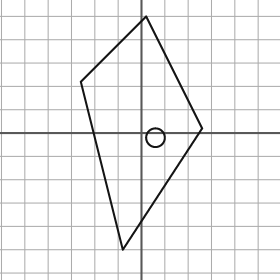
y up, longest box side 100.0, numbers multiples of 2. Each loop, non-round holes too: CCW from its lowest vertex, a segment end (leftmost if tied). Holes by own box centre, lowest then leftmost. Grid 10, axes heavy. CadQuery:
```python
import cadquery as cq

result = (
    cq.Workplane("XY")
    .moveTo(-8.0, -50.0)
    .lineTo(26.0, 2.0)
    .lineTo(2.0, 50.0)
    .lineTo(-26.0, 22.0)
    .close()
    .moveTo(6.0, -2.0)
    .circle(4.0)
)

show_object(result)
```